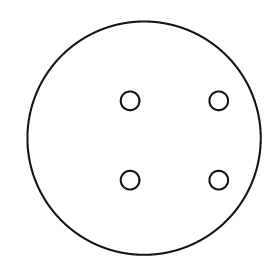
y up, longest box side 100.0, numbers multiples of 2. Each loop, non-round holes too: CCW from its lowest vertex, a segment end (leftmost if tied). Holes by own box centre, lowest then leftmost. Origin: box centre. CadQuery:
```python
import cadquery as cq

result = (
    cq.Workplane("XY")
    .moveTo(0.0, 0.0)
    .circle(50.0)
    .moveTo(-6.0, -18.0)
    .circle(4.0)
    .moveTo(32.0, -18.0)
    .circle(4.0)
    .moveTo(-6.0, 16.0)
    .circle(4.0)
    .moveTo(32.0, 16.0)
    .circle(4.0)
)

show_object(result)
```